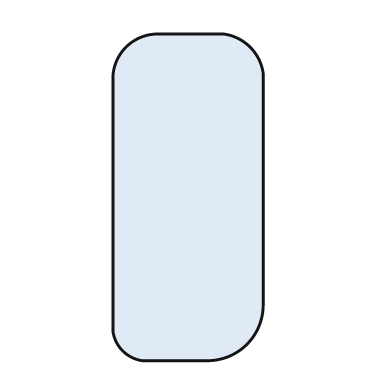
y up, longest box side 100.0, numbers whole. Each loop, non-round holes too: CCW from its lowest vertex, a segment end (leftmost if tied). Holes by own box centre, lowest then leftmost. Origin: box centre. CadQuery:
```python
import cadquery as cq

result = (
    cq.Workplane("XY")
    .moveTo(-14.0, -50.0)
    .lineTo(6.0, -50.0)
    .threePointArc((18.0, -45.0), (23.0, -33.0))
    .lineTo(23.0, 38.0)
    .threePointArc((19.0, 46.0), (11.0, 50.0))
    .lineTo(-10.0, 50.0)
    .threePointArc((-19.0, 46.0), (-23.0, 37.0))
    .lineTo(-23.0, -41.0)
    .threePointArc((-20.0, -47.0), (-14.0, -50.0))
    .close()
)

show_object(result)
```